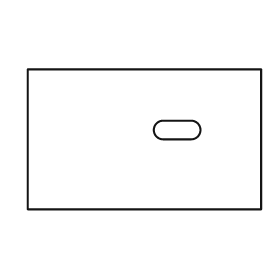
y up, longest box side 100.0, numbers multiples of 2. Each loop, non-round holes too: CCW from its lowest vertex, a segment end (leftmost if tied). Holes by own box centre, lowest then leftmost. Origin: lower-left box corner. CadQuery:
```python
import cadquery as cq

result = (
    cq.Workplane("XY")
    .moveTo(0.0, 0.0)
    .lineTo(100.0, 0.0)
    .lineTo(100.0, 60.0)
    .lineTo(0.0, 60.0)
    .close()
    .moveTo(58.0, 30.0)
    .lineTo(70.0, 30.0)
    .threePointArc((74.0, 34.0), (70.0, 38.0))
    .lineTo(58.0, 38.0)
    .threePointArc((54.0, 34.0), (58.0, 30.0))
    .close()
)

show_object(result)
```